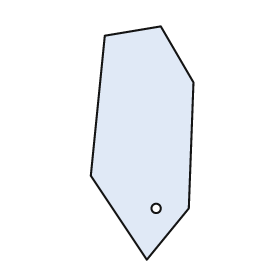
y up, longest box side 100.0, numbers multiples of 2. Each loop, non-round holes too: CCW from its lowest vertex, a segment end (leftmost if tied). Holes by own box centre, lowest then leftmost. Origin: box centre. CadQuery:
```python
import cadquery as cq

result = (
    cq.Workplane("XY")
    .moveTo(2.0, -50.0)
    .lineTo(20.0, -28.0)
    .lineTo(22.0, 26.0)
    .lineTo(8.0, 50.0)
    .lineTo(-16.0, 46.0)
    .lineTo(-22.0, -14.0)
    .close()
    .moveTo(6.0, -28.0)
    .circle(2.0)
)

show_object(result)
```